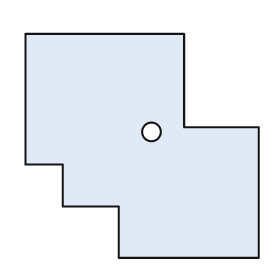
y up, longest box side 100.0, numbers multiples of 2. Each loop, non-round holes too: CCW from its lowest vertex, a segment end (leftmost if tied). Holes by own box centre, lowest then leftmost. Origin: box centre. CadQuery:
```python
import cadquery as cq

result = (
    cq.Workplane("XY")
    .moveTo(-10.0, -48.0)
    .lineTo(50.0, -48.0)
    .lineTo(50.0, 8.0)
    .lineTo(18.0, 8.0)
    .lineTo(18.0, 48.0)
    .lineTo(-50.0, 48.0)
    .lineTo(-50.0, -8.0)
    .lineTo(-34.0, -8.0)
    .lineTo(-34.0, -26.0)
    .lineTo(-10.0, -26.0)
    .close()
    .moveTo(4.0, 6.0)
    .circle(4.0)
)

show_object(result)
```